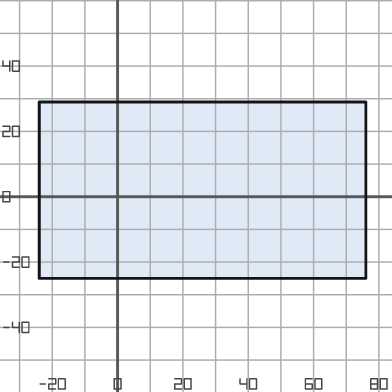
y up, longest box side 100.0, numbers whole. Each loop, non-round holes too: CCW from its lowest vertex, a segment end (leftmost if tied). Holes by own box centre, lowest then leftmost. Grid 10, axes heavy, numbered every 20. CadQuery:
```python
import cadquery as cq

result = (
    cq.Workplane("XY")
    .moveTo(-24.0, -25.0)
    .lineTo(76.0, -25.0)
    .lineTo(76.0, 29.0)
    .lineTo(-24.0, 29.0)
    .close()
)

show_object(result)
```